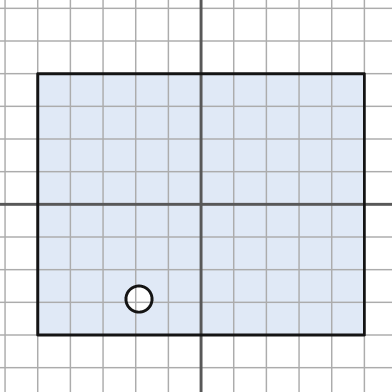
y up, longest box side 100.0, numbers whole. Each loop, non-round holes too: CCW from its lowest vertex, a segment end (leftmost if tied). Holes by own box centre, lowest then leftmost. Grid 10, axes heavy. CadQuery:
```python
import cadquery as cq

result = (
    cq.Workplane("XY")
    .moveTo(-50.0, -40.0)
    .lineTo(50.0, -40.0)
    .lineTo(50.0, 40.0)
    .lineTo(-50.0, 40.0)
    .close()
    .moveTo(-19.0, -29.0)
    .circle(4.0)
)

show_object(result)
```